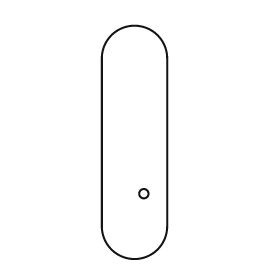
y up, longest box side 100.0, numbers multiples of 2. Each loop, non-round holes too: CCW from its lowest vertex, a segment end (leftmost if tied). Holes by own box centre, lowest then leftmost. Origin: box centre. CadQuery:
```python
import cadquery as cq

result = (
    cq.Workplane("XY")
    .moveTo(-14.0, -36.0)
    .threePointArc((0.0, -50.0), (14.0, -36.0))
    .lineTo(14.0, 36.0)
    .threePointArc((0.0, 50.0), (-14.0, 36.0))
    .close()
    .moveTo(4.0, -22.0)
    .circle(2.0)
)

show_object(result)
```